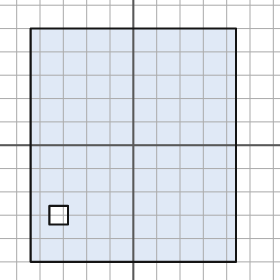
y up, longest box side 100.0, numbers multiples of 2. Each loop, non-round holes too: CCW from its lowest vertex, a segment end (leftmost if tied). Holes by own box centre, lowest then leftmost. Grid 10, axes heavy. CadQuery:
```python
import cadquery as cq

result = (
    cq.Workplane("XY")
    .moveTo(-44.0, -50.0)
    .lineTo(44.0, -50.0)
    .lineTo(44.0, 50.0)
    .lineTo(-44.0, 50.0)
    .close()
    .moveTo(-36.0, -34.0)
    .lineTo(-28.0, -34.0)
    .lineTo(-28.0, -26.0)
    .lineTo(-36.0, -26.0)
    .close()
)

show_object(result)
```